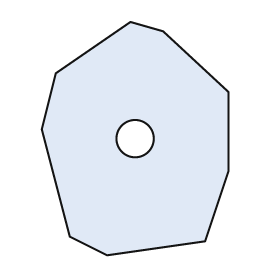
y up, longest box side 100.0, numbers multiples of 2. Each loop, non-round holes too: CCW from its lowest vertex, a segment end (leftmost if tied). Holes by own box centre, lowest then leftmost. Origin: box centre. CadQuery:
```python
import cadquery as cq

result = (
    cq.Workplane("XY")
    .moveTo(-12.0, -50.0)
    .lineTo(30.0, -44.0)
    .lineTo(40.0, -14.0)
    .lineTo(40.0, 20.0)
    .lineTo(12.0, 46.0)
    .lineTo(-2.0, 50.0)
    .lineTo(-34.0, 28.0)
    .lineTo(-40.0, 4.0)
    .lineTo(-28.0, -42.0)
    .close()
    .moveTo(0.0, 0.0)
    .circle(8.0)
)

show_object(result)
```